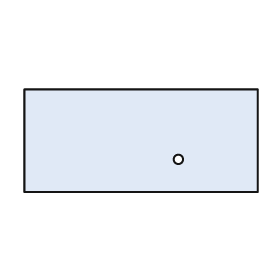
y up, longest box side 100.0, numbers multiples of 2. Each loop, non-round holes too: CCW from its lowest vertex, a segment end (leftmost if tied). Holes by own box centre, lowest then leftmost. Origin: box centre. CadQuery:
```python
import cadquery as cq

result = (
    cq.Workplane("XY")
    .moveTo(-50.0, -22.0)
    .lineTo(50.0, -22.0)
    .lineTo(50.0, 22.0)
    .lineTo(-50.0, 22.0)
    .close()
    .moveTo(16.0, -8.0)
    .circle(2.0)
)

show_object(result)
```